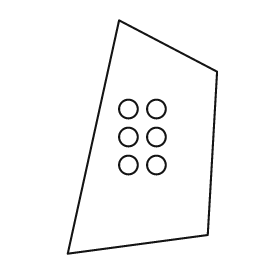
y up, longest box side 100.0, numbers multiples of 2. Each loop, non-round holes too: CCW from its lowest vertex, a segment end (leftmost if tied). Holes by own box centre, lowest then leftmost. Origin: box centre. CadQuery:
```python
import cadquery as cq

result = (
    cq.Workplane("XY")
    .moveTo(-32.0, -50.0)
    .lineTo(28.0, -42.0)
    .lineTo(32.0, 28.0)
    .lineTo(-10.0, 50.0)
    .close()
    .moveTo(-6.0, -12.0)
    .circle(4.0)
    .moveTo(6.0, -12.0)
    .circle(4.0)
    .moveTo(-6.0, 0.0)
    .circle(4.0)
    .moveTo(6.0, 0.0)
    .circle(4.0)
    .moveTo(-6.0, 12.0)
    .circle(4.0)
    .moveTo(6.0, 12.0)
    .circle(4.0)
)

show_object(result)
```